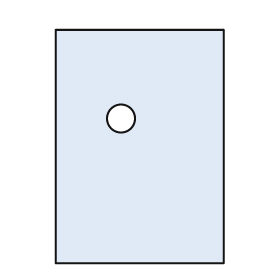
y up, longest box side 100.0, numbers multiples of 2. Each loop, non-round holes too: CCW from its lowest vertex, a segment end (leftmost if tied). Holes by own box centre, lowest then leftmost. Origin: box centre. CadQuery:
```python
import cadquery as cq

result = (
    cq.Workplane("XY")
    .moveTo(-36.0, -50.0)
    .lineTo(36.0, -50.0)
    .lineTo(36.0, 50.0)
    .lineTo(-36.0, 50.0)
    .close()
    .moveTo(-8.0, 12.0)
    .circle(6.0)
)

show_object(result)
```